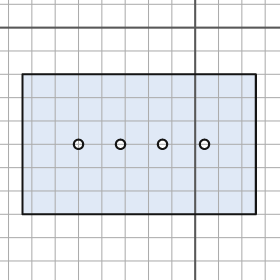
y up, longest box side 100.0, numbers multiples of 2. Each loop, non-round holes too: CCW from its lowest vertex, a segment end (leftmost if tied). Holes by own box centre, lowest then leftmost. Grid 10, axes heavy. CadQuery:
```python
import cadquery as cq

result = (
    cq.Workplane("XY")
    .moveTo(-74.0, -80.0)
    .lineTo(26.0, -80.0)
    .lineTo(26.0, -20.0)
    .lineTo(-74.0, -20.0)
    .close()
    .moveTo(-50.0, -50.0)
    .circle(2.0)
    .moveTo(-32.0, -50.0)
    .circle(2.0)
    .moveTo(-14.0, -50.0)
    .circle(2.0)
    .moveTo(4.0, -50.0)
    .circle(2.0)
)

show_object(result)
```